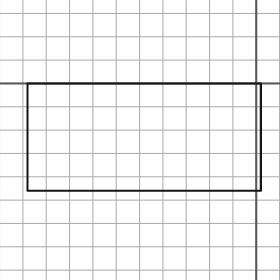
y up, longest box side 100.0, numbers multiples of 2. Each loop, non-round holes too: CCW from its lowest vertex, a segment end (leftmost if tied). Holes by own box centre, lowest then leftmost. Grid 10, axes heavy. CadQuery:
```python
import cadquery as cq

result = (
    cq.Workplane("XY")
    .moveTo(-98.0, -46.0)
    .lineTo(2.0, -46.0)
    .lineTo(2.0, 0.0)
    .lineTo(-98.0, 0.0)
    .close()
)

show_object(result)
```